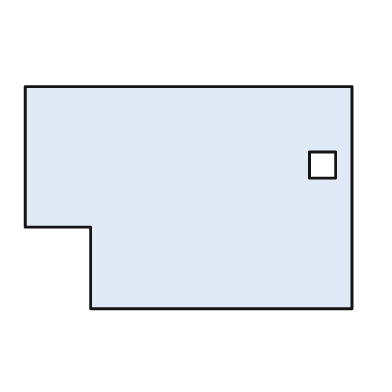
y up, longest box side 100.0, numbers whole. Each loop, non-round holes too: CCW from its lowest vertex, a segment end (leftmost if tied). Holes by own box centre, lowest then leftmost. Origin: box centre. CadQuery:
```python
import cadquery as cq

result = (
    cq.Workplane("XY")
    .moveTo(-30.0, -34.0)
    .lineTo(50.0, -34.0)
    .lineTo(50.0, 34.0)
    .lineTo(-50.0, 34.0)
    .lineTo(-50.0, -9.0)
    .lineTo(-30.0, -9.0)
    .close()
    .moveTo(37.0, 6.0)
    .lineTo(45.0, 6.0)
    .lineTo(45.0, 14.0)
    .lineTo(37.0, 14.0)
    .close()
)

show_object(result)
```